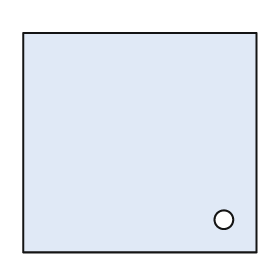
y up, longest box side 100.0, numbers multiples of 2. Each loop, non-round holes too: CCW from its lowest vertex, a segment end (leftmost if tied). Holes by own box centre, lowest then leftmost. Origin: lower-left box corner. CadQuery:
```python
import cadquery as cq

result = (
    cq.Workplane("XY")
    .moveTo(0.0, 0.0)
    .lineTo(100.0, 0.0)
    .lineTo(100.0, 94.0)
    .lineTo(0.0, 94.0)
    .close()
    .moveTo(86.0, 14.0)
    .circle(4.0)
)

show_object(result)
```